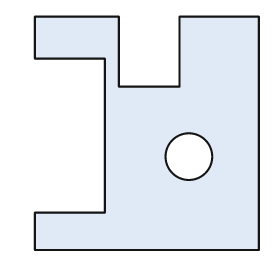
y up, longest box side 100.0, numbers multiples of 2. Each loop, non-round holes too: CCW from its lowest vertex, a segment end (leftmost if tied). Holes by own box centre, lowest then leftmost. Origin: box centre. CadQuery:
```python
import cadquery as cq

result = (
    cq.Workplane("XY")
    .moveTo(-48.0, -50.0)
    .lineTo(48.0, -50.0)
    .lineTo(48.0, 50.0)
    .lineTo(14.0, 50.0)
    .lineTo(14.0, 20.0)
    .lineTo(-12.0, 20.0)
    .lineTo(-12.0, 50.0)
    .lineTo(-48.0, 50.0)
    .lineTo(-48.0, 32.0)
    .lineTo(-18.0, 32.0)
    .lineTo(-18.0, -34.0)
    .lineTo(-48.0, -34.0)
    .close()
    .moveTo(18.0, -10.0)
    .circle(10.0)
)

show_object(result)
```